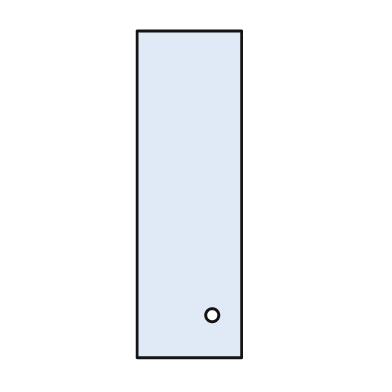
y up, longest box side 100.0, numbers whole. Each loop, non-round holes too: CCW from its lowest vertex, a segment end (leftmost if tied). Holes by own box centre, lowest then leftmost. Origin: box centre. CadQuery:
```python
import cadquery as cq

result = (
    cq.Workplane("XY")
    .moveTo(-16.0, -50.0)
    .lineTo(16.0, -50.0)
    .lineTo(16.0, 50.0)
    .lineTo(-16.0, 50.0)
    .close()
    .moveTo(7.0, -37.0)
    .circle(2.0)
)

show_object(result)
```